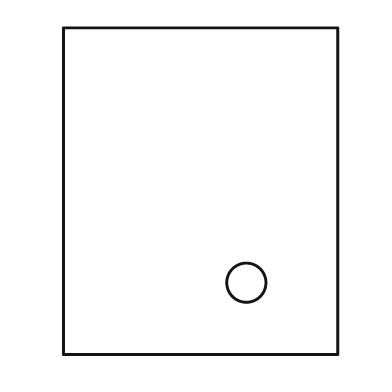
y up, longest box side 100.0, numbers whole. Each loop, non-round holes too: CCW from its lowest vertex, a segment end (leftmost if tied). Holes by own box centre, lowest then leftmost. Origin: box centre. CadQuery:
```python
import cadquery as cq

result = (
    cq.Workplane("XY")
    .moveTo(-42.0, -50.0)
    .lineTo(42.0, -50.0)
    .lineTo(42.0, 50.0)
    .lineTo(-42.0, 50.0)
    .close()
    .moveTo(14.0, -28.0)
    .circle(6.0)
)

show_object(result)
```